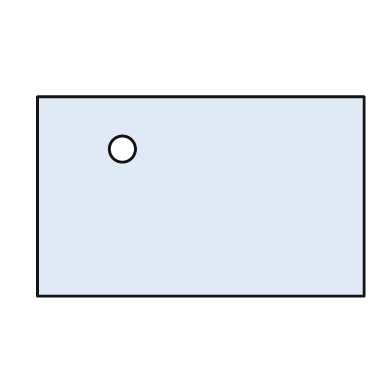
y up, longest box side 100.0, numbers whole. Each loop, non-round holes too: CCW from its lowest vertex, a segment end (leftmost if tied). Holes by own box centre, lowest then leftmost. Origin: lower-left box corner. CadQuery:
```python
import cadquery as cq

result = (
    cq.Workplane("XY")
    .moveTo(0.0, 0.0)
    .lineTo(100.0, 0.0)
    .lineTo(100.0, 61.0)
    .lineTo(0.0, 61.0)
    .close()
    .moveTo(26.0, 45.0)
    .circle(4.0)
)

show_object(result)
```